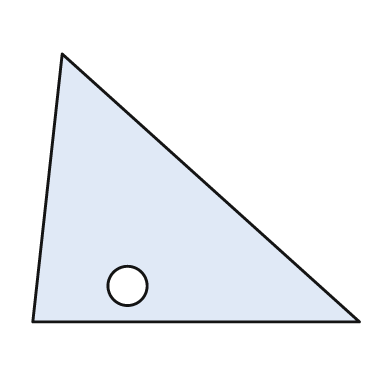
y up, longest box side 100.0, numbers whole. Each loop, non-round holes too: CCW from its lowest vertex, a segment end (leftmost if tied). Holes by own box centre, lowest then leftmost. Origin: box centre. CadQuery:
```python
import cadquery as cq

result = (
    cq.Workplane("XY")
    .moveTo(-50.0, -41.0)
    .lineTo(50.0, -41.0)
    .lineTo(-41.0, 41.0)
    .close()
    .moveTo(-21.0, -30.0)
    .circle(6.0)
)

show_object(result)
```